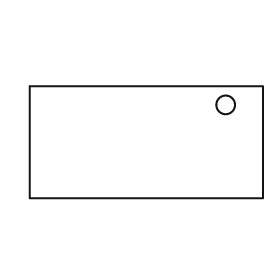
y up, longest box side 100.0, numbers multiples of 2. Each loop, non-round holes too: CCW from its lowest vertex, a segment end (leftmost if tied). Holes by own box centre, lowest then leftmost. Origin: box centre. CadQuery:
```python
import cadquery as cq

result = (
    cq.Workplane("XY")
    .moveTo(-50.0, -24.0)
    .lineTo(50.0, -24.0)
    .lineTo(50.0, 24.0)
    .lineTo(-50.0, 24.0)
    .close()
    .moveTo(34.0, 16.0)
    .circle(4.0)
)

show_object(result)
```